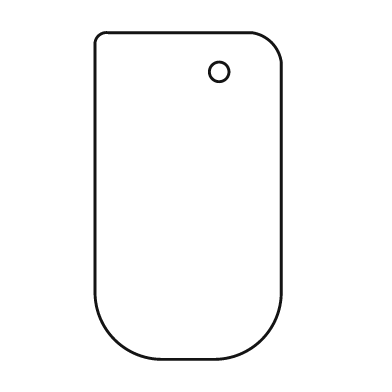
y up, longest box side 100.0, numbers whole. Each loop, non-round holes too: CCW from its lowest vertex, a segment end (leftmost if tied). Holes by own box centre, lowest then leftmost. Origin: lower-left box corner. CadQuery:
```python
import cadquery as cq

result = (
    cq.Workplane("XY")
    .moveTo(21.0, 0.0)
    .lineTo(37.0, 0.0)
    .threePointArc((51.0, 6.0), (57.0, 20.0))
    .lineTo(57.0, 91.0)
    .threePointArc((54.0, 97.0), (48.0, 100.0))
    .lineTo(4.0, 100.0)
    .threePointArc((1.0, 99.0), (0.0, 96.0))
    .lineTo(0.0, 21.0)
    .threePointArc((6.0, 6.0), (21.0, 0.0))
    .close()
    .moveTo(38.0, 88.0)
    .circle(3.0)
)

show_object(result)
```